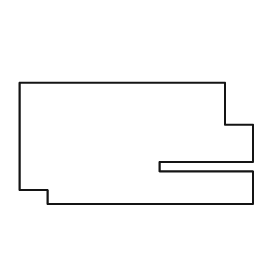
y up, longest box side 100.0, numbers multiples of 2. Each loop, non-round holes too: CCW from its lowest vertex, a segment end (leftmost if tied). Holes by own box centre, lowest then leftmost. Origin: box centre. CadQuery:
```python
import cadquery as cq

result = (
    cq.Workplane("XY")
    .moveTo(-38.0, -26.0)
    .lineTo(50.0, -26.0)
    .lineTo(50.0, -12.0)
    .lineTo(10.0, -12.0)
    .lineTo(10.0, -8.0)
    .lineTo(50.0, -8.0)
    .lineTo(50.0, 8.0)
    .lineTo(38.0, 8.0)
    .lineTo(38.0, 26.0)
    .lineTo(-50.0, 26.0)
    .lineTo(-50.0, -20.0)
    .lineTo(-38.0, -20.0)
    .close()
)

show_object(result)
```